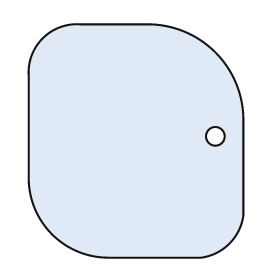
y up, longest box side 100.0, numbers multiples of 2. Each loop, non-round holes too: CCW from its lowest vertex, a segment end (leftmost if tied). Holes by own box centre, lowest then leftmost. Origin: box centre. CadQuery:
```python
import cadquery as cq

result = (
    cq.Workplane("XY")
    .moveTo(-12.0, -50.0)
    .lineTo(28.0, -50.0)
    .threePointArc((40.0, -44.0), (46.0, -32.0))
    .lineTo(46.0, 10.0)
    .threePointArc((34.0, 38.0), (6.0, 50.0))
    .lineTo(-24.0, 50.0)
    .threePointArc((-40.0, 44.0), (-46.0, 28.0))
    .lineTo(-46.0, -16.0)
    .threePointArc((-36.0, -40.0), (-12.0, -50.0))
    .close()
    .moveTo(34.0, 2.0)
    .circle(4.0)
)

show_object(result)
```